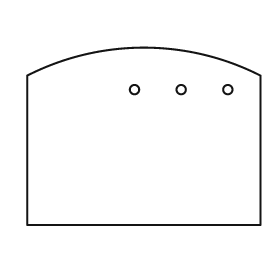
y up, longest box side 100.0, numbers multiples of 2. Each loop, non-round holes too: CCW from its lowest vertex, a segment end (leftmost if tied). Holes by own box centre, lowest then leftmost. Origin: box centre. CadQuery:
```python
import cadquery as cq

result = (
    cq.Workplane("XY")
    .moveTo(-50.0, -38.0)
    .lineTo(50.0, -38.0)
    .lineTo(50.0, 26.0)
    .threePointArc((0.0, 38.0), (-50.0, 26.0))
    .close()
    .moveTo(-4.0, 20.0)
    .circle(2.0)
    .moveTo(16.0, 20.0)
    .circle(2.0)
    .moveTo(36.0, 20.0)
    .circle(2.0)
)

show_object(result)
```